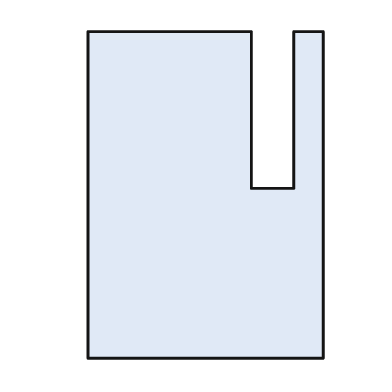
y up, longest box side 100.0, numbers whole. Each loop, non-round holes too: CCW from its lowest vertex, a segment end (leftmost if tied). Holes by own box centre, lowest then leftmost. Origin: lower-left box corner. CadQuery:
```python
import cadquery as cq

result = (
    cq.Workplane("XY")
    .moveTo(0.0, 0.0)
    .lineTo(72.0, 0.0)
    .lineTo(72.0, 100.0)
    .lineTo(63.0, 100.0)
    .lineTo(63.0, 52.0)
    .lineTo(50.0, 52.0)
    .lineTo(50.0, 100.0)
    .lineTo(0.0, 100.0)
    .close()
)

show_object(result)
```